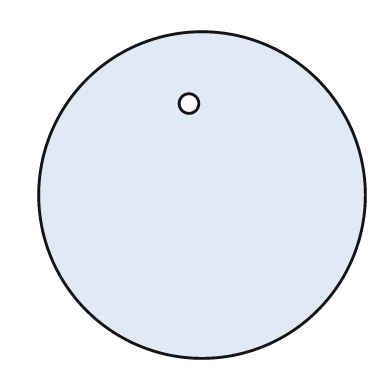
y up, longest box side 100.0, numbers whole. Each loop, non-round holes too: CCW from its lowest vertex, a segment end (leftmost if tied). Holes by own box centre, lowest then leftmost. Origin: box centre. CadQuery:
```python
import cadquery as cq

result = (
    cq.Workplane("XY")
    .moveTo(0.0, 0.0)
    .circle(50.0)
    .moveTo(-4.0, 28.0)
    .circle(3.0)
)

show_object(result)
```